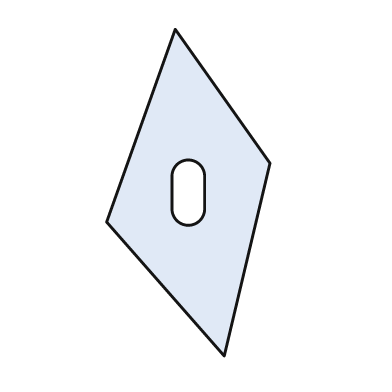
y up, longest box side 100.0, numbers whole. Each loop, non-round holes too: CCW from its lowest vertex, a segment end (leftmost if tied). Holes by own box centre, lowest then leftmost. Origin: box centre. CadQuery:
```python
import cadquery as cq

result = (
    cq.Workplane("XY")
    .moveTo(11.0, -50.0)
    .lineTo(25.0, 9.0)
    .lineTo(-4.0, 50.0)
    .lineTo(-25.0, -9.0)
    .close()
    .moveTo(-5.0, -5.0)
    .threePointArc((0.0, -10.0), (5.0, -5.0))
    .lineTo(5.0, 5.0)
    .threePointArc((0.0, 10.0), (-5.0, 5.0))
    .close()
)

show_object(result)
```